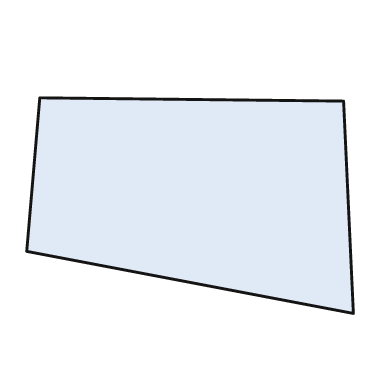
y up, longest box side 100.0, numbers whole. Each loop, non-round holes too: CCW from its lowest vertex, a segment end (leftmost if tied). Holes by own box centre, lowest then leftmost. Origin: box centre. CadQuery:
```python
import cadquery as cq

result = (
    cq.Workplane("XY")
    .moveTo(50.0, -33.0)
    .lineTo(47.0, 32.0)
    .lineTo(-46.0, 33.0)
    .lineTo(-50.0, -14.0)
    .close()
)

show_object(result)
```